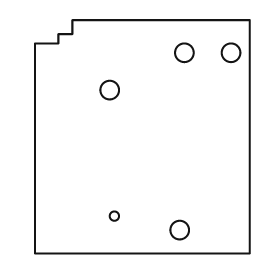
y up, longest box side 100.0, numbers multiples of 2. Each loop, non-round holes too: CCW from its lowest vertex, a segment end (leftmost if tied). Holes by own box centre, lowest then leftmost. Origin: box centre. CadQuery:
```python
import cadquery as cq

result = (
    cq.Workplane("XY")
    .moveTo(-46.0, -50.0)
    .lineTo(46.0, -50.0)
    .lineTo(46.0, 50.0)
    .lineTo(-30.0, 50.0)
    .lineTo(-30.0, 44.0)
    .lineTo(-36.0, 44.0)
    .lineTo(-36.0, 40.0)
    .lineTo(-46.0, 40.0)
    .close()
    .moveTo(16.0, -40.0)
    .circle(4.0)
    .moveTo(-12.0, -34.0)
    .circle(2.0)
    .moveTo(-14.0, 20.0)
    .circle(4.0)
    .moveTo(18.0, 36.0)
    .circle(4.0)
    .moveTo(38.0, 36.0)
    .circle(4.0)
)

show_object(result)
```